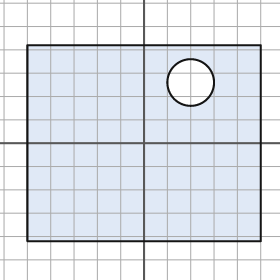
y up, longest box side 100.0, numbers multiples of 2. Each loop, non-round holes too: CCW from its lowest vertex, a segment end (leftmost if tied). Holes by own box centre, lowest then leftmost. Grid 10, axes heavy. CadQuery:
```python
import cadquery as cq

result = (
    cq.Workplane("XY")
    .moveTo(-50.0, -42.0)
    .lineTo(50.0, -42.0)
    .lineTo(50.0, 42.0)
    .lineTo(-50.0, 42.0)
    .close()
    .moveTo(20.0, 26.0)
    .circle(10.0)
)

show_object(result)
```